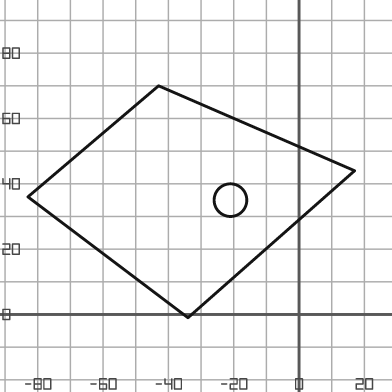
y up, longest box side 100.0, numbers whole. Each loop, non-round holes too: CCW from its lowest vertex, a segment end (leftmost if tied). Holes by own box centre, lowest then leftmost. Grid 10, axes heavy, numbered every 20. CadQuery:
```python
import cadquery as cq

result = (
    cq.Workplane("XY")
    .moveTo(-34.0, -1.0)
    .lineTo(17.0, 44.0)
    .lineTo(-43.0, 70.0)
    .lineTo(-83.0, 36.0)
    .close()
    .moveTo(-21.0, 35.0)
    .circle(5.0)
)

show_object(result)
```